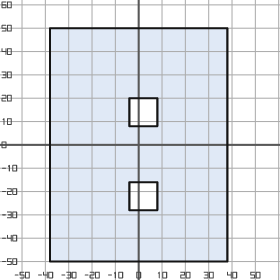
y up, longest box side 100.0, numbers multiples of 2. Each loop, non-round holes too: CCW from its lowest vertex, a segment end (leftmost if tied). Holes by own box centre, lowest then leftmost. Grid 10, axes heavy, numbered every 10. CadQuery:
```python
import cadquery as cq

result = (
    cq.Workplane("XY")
    .moveTo(-38.0, -50.0)
    .lineTo(38.0, -50.0)
    .lineTo(38.0, 50.0)
    .lineTo(-38.0, 50.0)
    .close()
    .moveTo(-4.0, -28.0)
    .lineTo(8.0, -28.0)
    .lineTo(8.0, -16.0)
    .lineTo(-4.0, -16.0)
    .close()
    .moveTo(-4.0, 8.0)
    .lineTo(8.0, 8.0)
    .lineTo(8.0, 20.0)
    .lineTo(-4.0, 20.0)
    .close()
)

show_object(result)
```